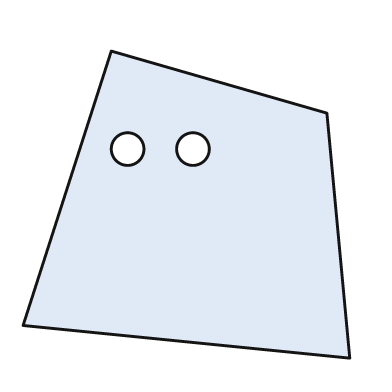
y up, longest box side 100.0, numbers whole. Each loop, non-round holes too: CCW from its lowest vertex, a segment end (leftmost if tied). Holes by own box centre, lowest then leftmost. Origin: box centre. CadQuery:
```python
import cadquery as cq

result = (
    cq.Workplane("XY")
    .moveTo(50.0, -47.0)
    .lineTo(43.0, 28.0)
    .lineTo(-23.0, 47.0)
    .lineTo(-50.0, -37.0)
    .close()
    .moveTo(-18.0, 17.0)
    .circle(5.0)
    .moveTo(2.0, 17.0)
    .circle(5.0)
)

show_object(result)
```